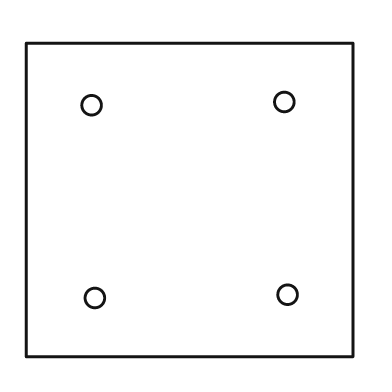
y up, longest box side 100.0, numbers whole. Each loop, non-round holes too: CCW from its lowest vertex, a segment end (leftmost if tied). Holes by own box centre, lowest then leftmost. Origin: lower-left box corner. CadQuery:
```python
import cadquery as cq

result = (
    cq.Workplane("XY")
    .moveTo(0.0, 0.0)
    .lineTo(100.0, 0.0)
    .lineTo(100.0, 96.0)
    .lineTo(0.0, 96.0)
    .close()
    .moveTo(21.0, 18.0)
    .circle(3.0)
    .moveTo(80.0, 19.0)
    .circle(3.0)
    .moveTo(20.0, 77.0)
    .circle(3.0)
    .moveTo(79.0, 78.0)
    .circle(3.0)
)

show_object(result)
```